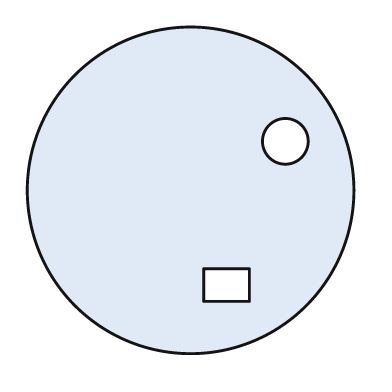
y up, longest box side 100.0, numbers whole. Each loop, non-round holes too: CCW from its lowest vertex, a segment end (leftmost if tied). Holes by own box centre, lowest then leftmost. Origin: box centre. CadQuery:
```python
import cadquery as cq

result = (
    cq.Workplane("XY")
    .moveTo(0.0, 0.0)
    .circle(50.0)
    .moveTo(4.0, -34.0)
    .lineTo(18.0, -34.0)
    .lineTo(18.0, -24.0)
    .lineTo(4.0, -24.0)
    .close()
    .moveTo(29.0, 15.0)
    .circle(7.0)
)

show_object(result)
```